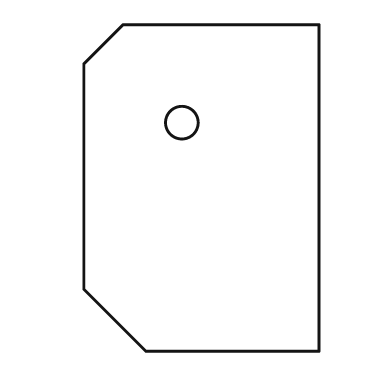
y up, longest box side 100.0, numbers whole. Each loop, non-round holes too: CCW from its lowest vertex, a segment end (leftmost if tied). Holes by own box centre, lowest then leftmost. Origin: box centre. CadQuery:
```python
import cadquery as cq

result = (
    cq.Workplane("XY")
    .moveTo(-17.0, -50.0)
    .lineTo(36.0, -50.0)
    .lineTo(36.0, 50.0)
    .lineTo(-24.0, 50.0)
    .lineTo(-36.0, 38.0)
    .lineTo(-36.0, -31.0)
    .close()
    .moveTo(-6.0, 20.0)
    .circle(5.0)
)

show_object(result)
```